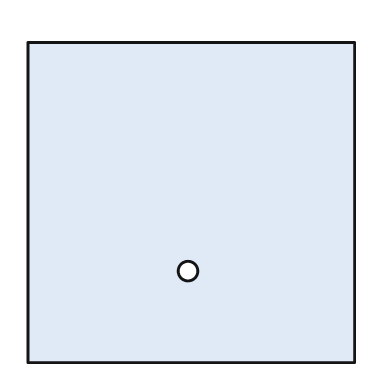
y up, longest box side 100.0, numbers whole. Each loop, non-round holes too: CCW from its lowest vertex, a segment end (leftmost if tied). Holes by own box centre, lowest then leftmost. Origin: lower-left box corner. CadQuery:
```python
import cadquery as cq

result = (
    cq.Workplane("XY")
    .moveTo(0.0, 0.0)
    .lineTo(100.0, 0.0)
    .lineTo(100.0, 98.0)
    .lineTo(0.0, 98.0)
    .close()
    .moveTo(49.0, 28.0)
    .circle(3.0)
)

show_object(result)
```